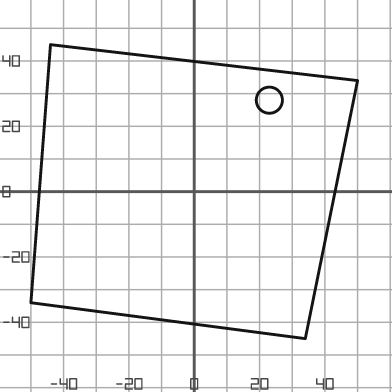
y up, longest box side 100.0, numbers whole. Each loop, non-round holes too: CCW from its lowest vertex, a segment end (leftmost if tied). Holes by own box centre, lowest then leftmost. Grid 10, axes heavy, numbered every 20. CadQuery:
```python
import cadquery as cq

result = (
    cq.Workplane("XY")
    .moveTo(34.0, -45.0)
    .lineTo(50.0, 34.0)
    .lineTo(-44.0, 45.0)
    .lineTo(-50.0, -34.0)
    .close()
    .moveTo(23.0, 28.0)
    .circle(4.0)
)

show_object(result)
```